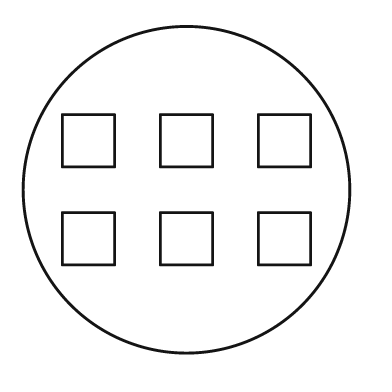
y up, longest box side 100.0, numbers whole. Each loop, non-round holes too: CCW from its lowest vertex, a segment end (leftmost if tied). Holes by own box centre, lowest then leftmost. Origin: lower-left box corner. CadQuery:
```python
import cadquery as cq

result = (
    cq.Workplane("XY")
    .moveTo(50.0, 50.0)
    .circle(50.0)
    .moveTo(12.0, 27.0)
    .lineTo(28.0, 27.0)
    .lineTo(28.0, 43.0)
    .lineTo(12.0, 43.0)
    .close()
    .moveTo(42.0, 27.0)
    .lineTo(58.0, 27.0)
    .lineTo(58.0, 43.0)
    .lineTo(42.0, 43.0)
    .close()
    .moveTo(72.0, 27.0)
    .lineTo(88.0, 27.0)
    .lineTo(88.0, 43.0)
    .lineTo(72.0, 43.0)
    .close()
    .moveTo(12.0, 57.0)
    .lineTo(28.0, 57.0)
    .lineTo(28.0, 73.0)
    .lineTo(12.0, 73.0)
    .close()
    .moveTo(42.0, 57.0)
    .lineTo(58.0, 57.0)
    .lineTo(58.0, 73.0)
    .lineTo(42.0, 73.0)
    .close()
    .moveTo(72.0, 57.0)
    .lineTo(88.0, 57.0)
    .lineTo(88.0, 73.0)
    .lineTo(72.0, 73.0)
    .close()
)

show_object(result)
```